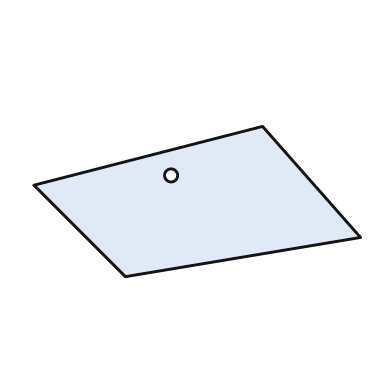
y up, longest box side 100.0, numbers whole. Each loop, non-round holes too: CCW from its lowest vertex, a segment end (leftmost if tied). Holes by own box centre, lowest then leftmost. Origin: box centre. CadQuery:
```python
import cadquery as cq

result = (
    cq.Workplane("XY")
    .moveTo(-22.0, -23.0)
    .lineTo(50.0, -11.0)
    .lineTo(20.0, 23.0)
    .lineTo(-50.0, 5.0)
    .close()
    .moveTo(-8.0, 8.0)
    .circle(2.0)
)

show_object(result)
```